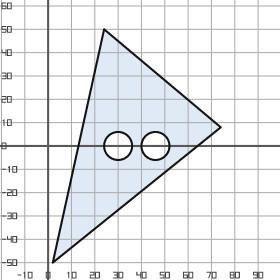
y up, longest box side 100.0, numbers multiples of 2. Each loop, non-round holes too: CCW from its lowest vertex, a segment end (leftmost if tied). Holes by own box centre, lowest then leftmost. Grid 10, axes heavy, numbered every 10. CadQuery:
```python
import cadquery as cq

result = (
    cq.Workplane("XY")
    .moveTo(2.0, -50.0)
    .lineTo(74.0, 8.0)
    .lineTo(24.0, 50.0)
    .close()
    .moveTo(30.0, 0.0)
    .circle(6.0)
    .moveTo(46.0, 0.0)
    .circle(6.0)
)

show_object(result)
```